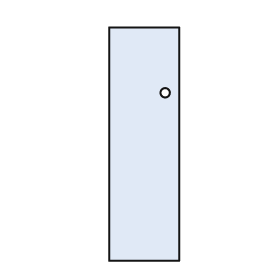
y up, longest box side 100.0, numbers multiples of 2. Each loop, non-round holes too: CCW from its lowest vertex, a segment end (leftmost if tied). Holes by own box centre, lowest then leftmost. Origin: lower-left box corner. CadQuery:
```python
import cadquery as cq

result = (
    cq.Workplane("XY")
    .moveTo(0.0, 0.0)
    .lineTo(30.0, 0.0)
    .lineTo(30.0, 100.0)
    .lineTo(0.0, 100.0)
    .close()
    .moveTo(24.0, 72.0)
    .circle(2.0)
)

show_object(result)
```